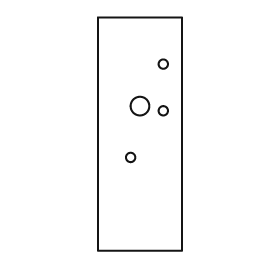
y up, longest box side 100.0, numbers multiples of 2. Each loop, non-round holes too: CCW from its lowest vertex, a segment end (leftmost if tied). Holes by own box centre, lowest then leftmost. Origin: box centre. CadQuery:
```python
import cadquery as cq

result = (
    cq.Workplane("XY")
    .moveTo(-18.0, -50.0)
    .lineTo(18.0, -50.0)
    .lineTo(18.0, 50.0)
    .lineTo(-18.0, 50.0)
    .close()
    .moveTo(-4.0, -10.0)
    .circle(2.0)
    .moveTo(10.0, 10.0)
    .circle(2.0)
    .moveTo(0.0, 12.0)
    .circle(4.0)
    .moveTo(10.0, 30.0)
    .circle(2.0)
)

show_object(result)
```